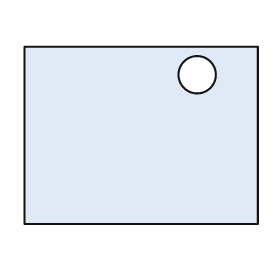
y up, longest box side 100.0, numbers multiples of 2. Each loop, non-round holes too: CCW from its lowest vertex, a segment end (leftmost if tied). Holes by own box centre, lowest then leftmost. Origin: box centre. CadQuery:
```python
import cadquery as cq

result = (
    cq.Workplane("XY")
    .moveTo(-50.0, -38.0)
    .lineTo(50.0, -38.0)
    .lineTo(50.0, 38.0)
    .lineTo(-50.0, 38.0)
    .close()
    .moveTo(24.0, 26.0)
    .circle(8.0)
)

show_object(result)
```